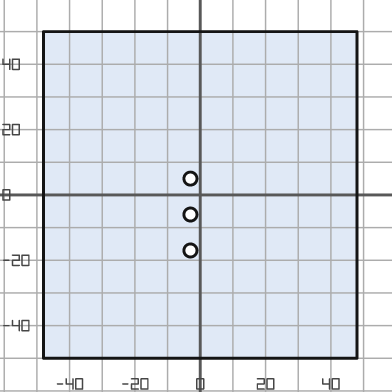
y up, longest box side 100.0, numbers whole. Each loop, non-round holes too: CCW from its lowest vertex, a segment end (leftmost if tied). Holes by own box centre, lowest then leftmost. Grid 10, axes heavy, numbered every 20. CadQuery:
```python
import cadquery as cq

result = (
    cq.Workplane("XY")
    .moveTo(-48.0, -50.0)
    .lineTo(48.0, -50.0)
    .lineTo(48.0, 50.0)
    .lineTo(-48.0, 50.0)
    .close()
    .moveTo(-3.0, -17.0)
    .circle(2.0)
    .moveTo(-3.0, -6.0)
    .circle(2.0)
    .moveTo(-3.0, 5.0)
    .circle(2.0)
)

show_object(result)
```